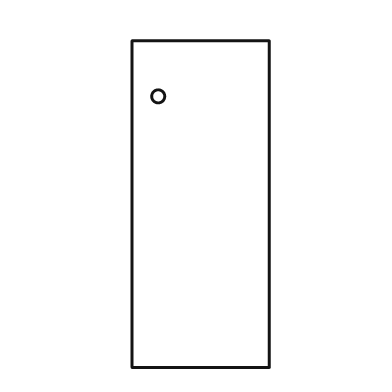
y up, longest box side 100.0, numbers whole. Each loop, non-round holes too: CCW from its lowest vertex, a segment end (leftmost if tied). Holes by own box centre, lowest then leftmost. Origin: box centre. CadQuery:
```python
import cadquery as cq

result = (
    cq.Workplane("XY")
    .moveTo(-21.0, -50.0)
    .lineTo(21.0, -50.0)
    .lineTo(21.0, 50.0)
    .lineTo(-21.0, 50.0)
    .close()
    .moveTo(-13.0, 33.0)
    .circle(2.0)
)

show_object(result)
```